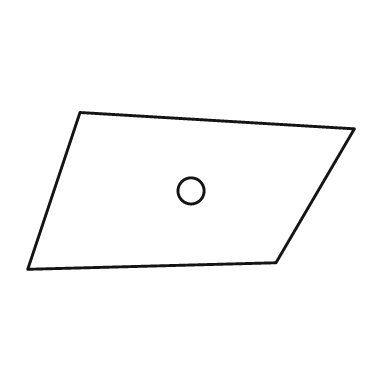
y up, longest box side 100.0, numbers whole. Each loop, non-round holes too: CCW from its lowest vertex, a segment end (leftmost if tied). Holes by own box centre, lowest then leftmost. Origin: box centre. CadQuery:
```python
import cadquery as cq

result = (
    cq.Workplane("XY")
    .moveTo(-50.0, -24.0)
    .lineTo(26.0, -22.0)
    .lineTo(50.0, 19.0)
    .lineTo(-34.0, 24.0)
    .close()
    .moveTo(0.0, 0.0)
    .circle(4.0)
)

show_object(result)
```